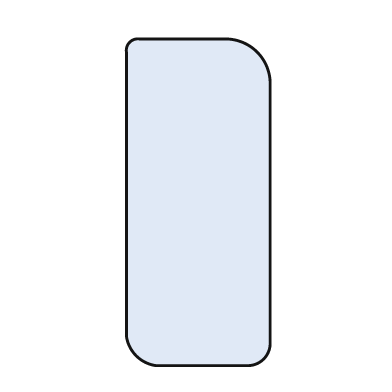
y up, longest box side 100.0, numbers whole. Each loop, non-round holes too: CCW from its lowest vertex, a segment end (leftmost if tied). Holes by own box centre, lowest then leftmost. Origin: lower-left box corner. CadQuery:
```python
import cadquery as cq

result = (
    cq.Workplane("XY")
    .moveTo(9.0, 0.0)
    .lineTo(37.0, 0.0)
    .threePointArc((42.0, 2.0), (44.0, 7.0))
    .lineTo(44.0, 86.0)
    .threePointArc((40.0, 96.0), (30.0, 100.0))
    .lineTo(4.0, 100.0)
    .threePointArc((1.0, 99.0), (0.0, 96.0))
    .lineTo(0.0, 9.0)
    .threePointArc((3.0, 3.0), (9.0, 0.0))
    .close()
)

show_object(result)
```